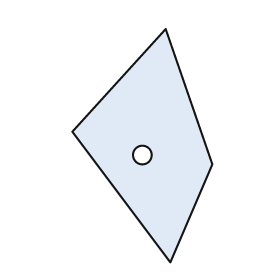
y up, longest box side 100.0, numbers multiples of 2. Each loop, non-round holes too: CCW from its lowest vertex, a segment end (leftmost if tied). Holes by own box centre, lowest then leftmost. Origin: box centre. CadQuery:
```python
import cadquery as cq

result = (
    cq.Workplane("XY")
    .moveTo(12.0, -50.0)
    .lineTo(30.0, -8.0)
    .lineTo(10.0, 50.0)
    .lineTo(-30.0, 6.0)
    .close()
    .moveTo(0.0, -4.0)
    .circle(4.0)
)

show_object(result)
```